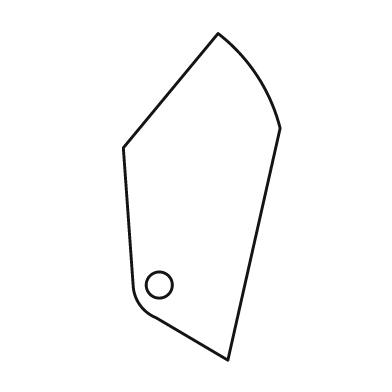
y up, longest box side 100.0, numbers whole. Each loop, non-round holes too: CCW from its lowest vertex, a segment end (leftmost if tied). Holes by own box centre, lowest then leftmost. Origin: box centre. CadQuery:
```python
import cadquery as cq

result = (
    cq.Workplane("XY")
    .moveTo(8.0, -50.0)
    .lineTo(24.0, 21.0)
    .threePointArc((17.0, 37.0), (5.0, 50.0))
    .lineTo(-24.0, 15.0)
    .lineTo(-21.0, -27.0)
    .threePointArc((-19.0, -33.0), (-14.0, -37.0))
    .close()
    .moveTo(-13.0, -27.0)
    .circle(4.0)
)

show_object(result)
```